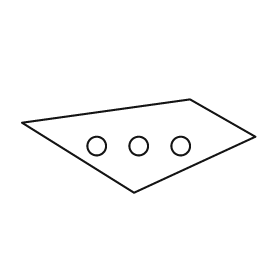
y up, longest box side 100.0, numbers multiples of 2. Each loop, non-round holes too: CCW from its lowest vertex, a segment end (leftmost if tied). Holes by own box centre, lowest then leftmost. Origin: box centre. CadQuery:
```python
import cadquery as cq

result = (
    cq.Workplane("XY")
    .moveTo(-2.0, -20.0)
    .lineTo(50.0, 4.0)
    .lineTo(22.0, 20.0)
    .lineTo(-50.0, 10.0)
    .close()
    .moveTo(-18.0, 0.0)
    .circle(4.0)
    .moveTo(0.0, 0.0)
    .circle(4.0)
    .moveTo(18.0, 0.0)
    .circle(4.0)
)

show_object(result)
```